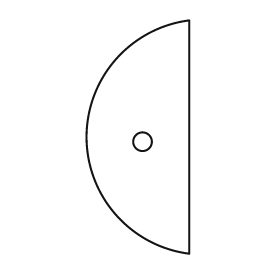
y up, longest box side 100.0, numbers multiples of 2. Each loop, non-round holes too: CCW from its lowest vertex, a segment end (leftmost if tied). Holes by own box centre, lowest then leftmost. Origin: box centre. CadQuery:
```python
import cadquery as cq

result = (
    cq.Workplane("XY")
    .moveTo(22.0, -50.0)
    .lineTo(22.0, 50.0)
    .threePointArc((-22.0, 0.0), (22.0, -50.0))
    .close()
    .moveTo(2.0, -2.0)
    .circle(4.0)
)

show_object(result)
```